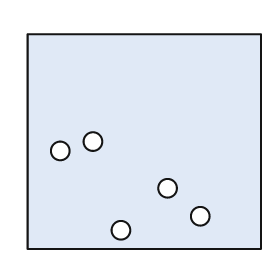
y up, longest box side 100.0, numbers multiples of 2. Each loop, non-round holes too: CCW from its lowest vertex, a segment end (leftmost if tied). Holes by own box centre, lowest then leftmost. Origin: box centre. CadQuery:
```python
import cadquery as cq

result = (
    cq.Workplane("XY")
    .moveTo(-50.0, -46.0)
    .lineTo(50.0, -46.0)
    .lineTo(50.0, 46.0)
    .lineTo(-50.0, 46.0)
    .close()
    .moveTo(-10.0, -38.0)
    .circle(4.0)
    .moveTo(24.0, -32.0)
    .circle(4.0)
    .moveTo(10.0, -20.0)
    .circle(4.0)
    .moveTo(-36.0, -4.0)
    .circle(4.0)
    .moveTo(-22.0, 0.0)
    .circle(4.0)
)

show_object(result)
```